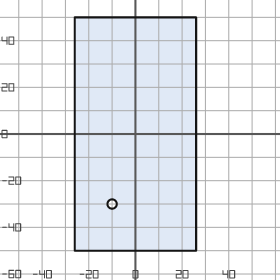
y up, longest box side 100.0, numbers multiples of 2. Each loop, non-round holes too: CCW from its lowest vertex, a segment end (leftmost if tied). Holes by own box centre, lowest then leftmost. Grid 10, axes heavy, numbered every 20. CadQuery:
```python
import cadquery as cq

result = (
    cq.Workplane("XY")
    .moveTo(-26.0, -50.0)
    .lineTo(26.0, -50.0)
    .lineTo(26.0, 50.0)
    .lineTo(-26.0, 50.0)
    .close()
    .moveTo(-10.0, -30.0)
    .circle(2.0)
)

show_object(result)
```